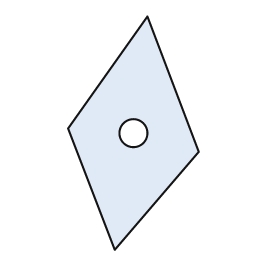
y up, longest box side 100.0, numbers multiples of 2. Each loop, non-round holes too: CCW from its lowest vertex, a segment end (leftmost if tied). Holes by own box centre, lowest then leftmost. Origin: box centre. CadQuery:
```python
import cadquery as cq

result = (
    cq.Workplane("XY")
    .moveTo(-8.0, -50.0)
    .lineTo(28.0, -8.0)
    .lineTo(6.0, 50.0)
    .lineTo(-28.0, 2.0)
    .close()
    .moveTo(0.0, 0.0)
    .circle(6.0)
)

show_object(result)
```